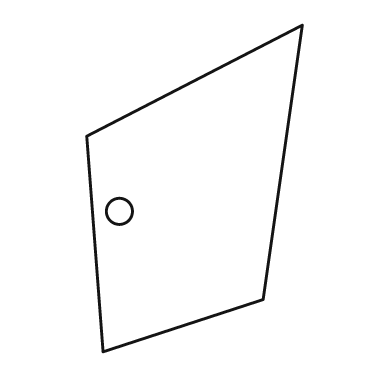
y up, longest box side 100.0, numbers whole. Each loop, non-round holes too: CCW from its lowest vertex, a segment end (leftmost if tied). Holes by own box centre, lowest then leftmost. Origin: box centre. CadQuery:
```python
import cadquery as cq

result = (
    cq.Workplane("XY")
    .moveTo(-28.0, -50.0)
    .lineTo(21.0, -34.0)
    .lineTo(33.0, 50.0)
    .lineTo(-33.0, 16.0)
    .close()
    .moveTo(-23.0, -7.0)
    .circle(4.0)
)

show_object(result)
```